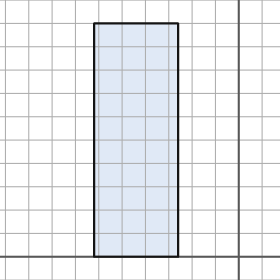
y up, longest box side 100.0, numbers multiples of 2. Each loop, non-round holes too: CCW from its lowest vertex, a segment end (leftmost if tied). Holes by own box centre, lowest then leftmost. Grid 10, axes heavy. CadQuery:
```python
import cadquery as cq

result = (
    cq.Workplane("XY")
    .moveTo(-62.0, 0.0)
    .lineTo(-26.0, 0.0)
    .lineTo(-26.0, 100.0)
    .lineTo(-62.0, 100.0)
    .close()
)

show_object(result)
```